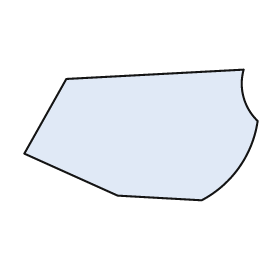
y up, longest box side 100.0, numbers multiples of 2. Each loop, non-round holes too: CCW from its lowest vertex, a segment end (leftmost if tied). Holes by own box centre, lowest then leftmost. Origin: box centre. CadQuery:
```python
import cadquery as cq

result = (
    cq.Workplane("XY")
    .moveTo(26.0, -28.0)
    .threePointArc((42.0, -14.0), (50.0, 6.0))
    .threePointArc((44.0, 16.0), (44.0, 28.0))
    .lineTo(-32.0, 24.0)
    .lineTo(-50.0, -8.0)
    .lineTo(-10.0, -26.0)
    .close()
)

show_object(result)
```